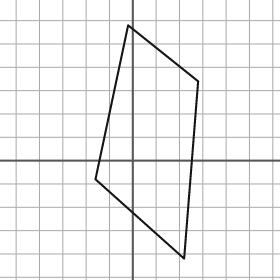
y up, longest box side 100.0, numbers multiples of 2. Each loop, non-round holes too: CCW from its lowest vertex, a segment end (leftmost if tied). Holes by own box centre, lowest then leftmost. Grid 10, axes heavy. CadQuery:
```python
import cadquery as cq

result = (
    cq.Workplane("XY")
    .moveTo(22.0, -42.0)
    .lineTo(28.0, 34.0)
    .lineTo(-2.0, 58.0)
    .lineTo(-16.0, -8.0)
    .close()
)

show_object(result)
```